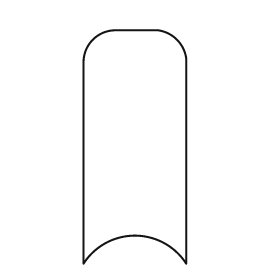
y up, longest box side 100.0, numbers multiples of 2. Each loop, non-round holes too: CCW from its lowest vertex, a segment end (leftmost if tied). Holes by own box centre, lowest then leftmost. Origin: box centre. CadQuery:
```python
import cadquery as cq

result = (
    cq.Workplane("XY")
    .moveTo(-22.0, -50.0)
    .threePointArc((0.0, -38.0), (22.0, -50.0))
    .lineTo(22.0, 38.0)
    .threePointArc((18.0, 46.0), (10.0, 50.0))
    .lineTo(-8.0, 50.0)
    .threePointArc((-18.0, 46.0), (-22.0, 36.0))
    .close()
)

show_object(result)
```